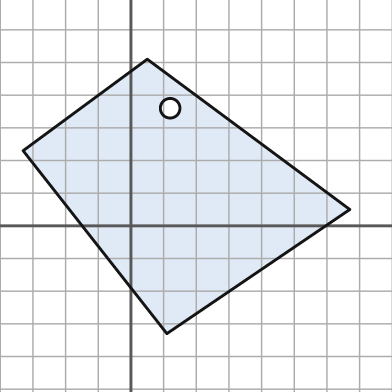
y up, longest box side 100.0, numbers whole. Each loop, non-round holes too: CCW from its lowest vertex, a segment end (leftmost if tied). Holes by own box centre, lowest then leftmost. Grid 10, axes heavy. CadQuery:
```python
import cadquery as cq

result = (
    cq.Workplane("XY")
    .moveTo(11.0, -33.0)
    .lineTo(67.0, 5.0)
    .lineTo(5.0, 51.0)
    .lineTo(-33.0, 23.0)
    .close()
    .moveTo(12.0, 36.0)
    .circle(3.0)
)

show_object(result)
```